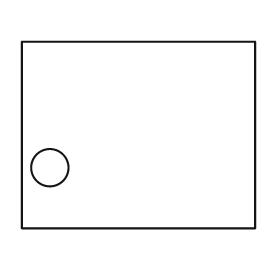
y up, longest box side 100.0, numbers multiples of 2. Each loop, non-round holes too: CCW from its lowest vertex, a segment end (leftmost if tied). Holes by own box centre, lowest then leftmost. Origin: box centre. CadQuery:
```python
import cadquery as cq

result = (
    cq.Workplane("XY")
    .moveTo(-50.0, -40.0)
    .lineTo(50.0, -40.0)
    .lineTo(50.0, 40.0)
    .lineTo(-50.0, 40.0)
    .close()
    .moveTo(-38.0, -14.0)
    .circle(8.0)
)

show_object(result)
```